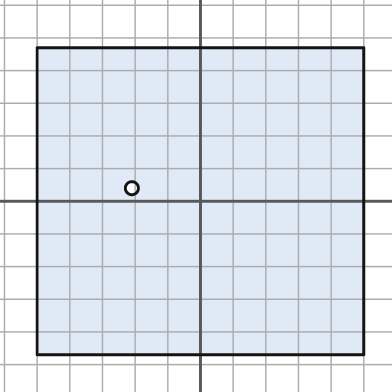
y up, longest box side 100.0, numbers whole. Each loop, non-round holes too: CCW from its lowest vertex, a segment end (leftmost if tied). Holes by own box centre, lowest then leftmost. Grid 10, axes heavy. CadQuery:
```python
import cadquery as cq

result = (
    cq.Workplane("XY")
    .moveTo(-50.0, -47.0)
    .lineTo(50.0, -47.0)
    .lineTo(50.0, 47.0)
    .lineTo(-50.0, 47.0)
    .close()
    .moveTo(-21.0, 4.0)
    .circle(2.0)
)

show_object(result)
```